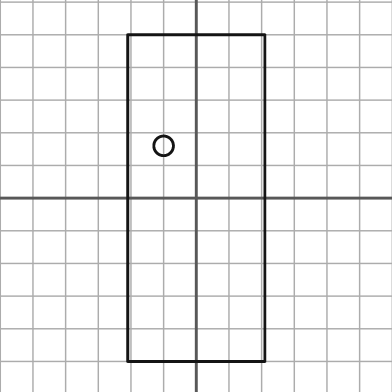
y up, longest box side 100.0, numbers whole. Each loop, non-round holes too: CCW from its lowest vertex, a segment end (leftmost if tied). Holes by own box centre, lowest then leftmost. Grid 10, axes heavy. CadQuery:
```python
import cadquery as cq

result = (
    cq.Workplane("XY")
    .moveTo(-21.0, -50.0)
    .lineTo(21.0, -50.0)
    .lineTo(21.0, 50.0)
    .lineTo(-21.0, 50.0)
    .close()
    .moveTo(-10.0, 16.0)
    .circle(3.0)
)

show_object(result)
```